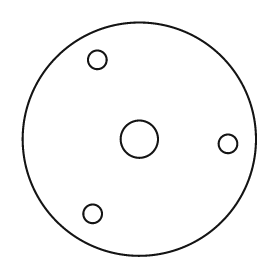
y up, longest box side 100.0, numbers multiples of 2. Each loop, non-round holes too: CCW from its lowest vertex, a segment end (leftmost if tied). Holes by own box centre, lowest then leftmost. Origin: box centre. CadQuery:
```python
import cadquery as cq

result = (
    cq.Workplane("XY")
    .moveTo(0.0, 0.0)
    .circle(50.0)
    .moveTo(-20.0, -32.0)
    .circle(4.0)
    .moveTo(38.0, -2.0)
    .circle(4.0)
    .moveTo(0.0, 0.0)
    .circle(8.0)
    .moveTo(-18.0, 34.0)
    .circle(4.0)
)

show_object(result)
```